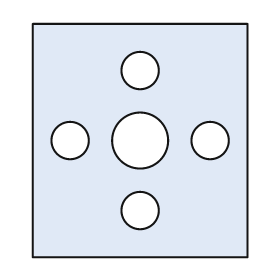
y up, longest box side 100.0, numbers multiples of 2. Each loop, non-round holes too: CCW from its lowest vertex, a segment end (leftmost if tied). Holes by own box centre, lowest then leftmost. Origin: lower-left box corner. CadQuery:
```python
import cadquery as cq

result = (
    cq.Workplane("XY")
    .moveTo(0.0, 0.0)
    .lineTo(92.0, 0.0)
    .lineTo(92.0, 100.0)
    .lineTo(0.0, 100.0)
    .close()
    .moveTo(46.0, 20.0)
    .circle(8.0)
    .moveTo(16.0, 50.0)
    .circle(8.0)
    .moveTo(46.0, 50.0)
    .circle(12.0)
    .moveTo(76.0, 50.0)
    .circle(8.0)
    .moveTo(46.0, 80.0)
    .circle(8.0)
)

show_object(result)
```